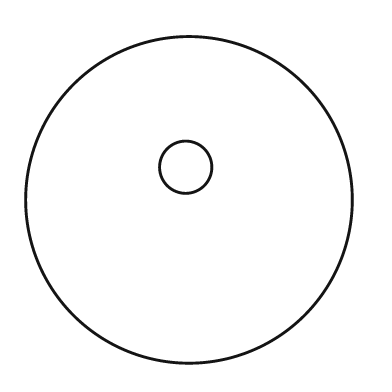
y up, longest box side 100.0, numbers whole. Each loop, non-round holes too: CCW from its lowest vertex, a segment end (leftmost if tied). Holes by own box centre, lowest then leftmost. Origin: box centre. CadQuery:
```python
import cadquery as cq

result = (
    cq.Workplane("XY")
    .moveTo(0.0, 0.0)
    .circle(50.0)
    .moveTo(-1.0, 10.0)
    .circle(8.0)
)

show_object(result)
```